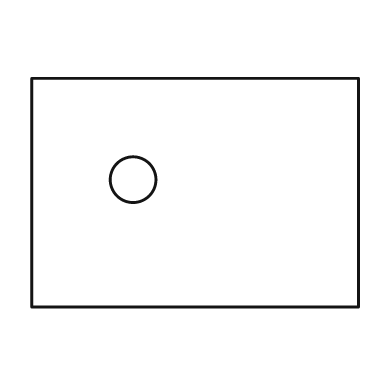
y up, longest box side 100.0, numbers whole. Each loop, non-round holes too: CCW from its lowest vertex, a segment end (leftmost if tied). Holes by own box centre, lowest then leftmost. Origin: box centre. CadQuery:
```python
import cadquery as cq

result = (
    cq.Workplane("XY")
    .moveTo(-50.0, -35.0)
    .lineTo(50.0, -35.0)
    .lineTo(50.0, 35.0)
    .lineTo(-50.0, 35.0)
    .close()
    .moveTo(-19.0, 4.0)
    .circle(7.0)
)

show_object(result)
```